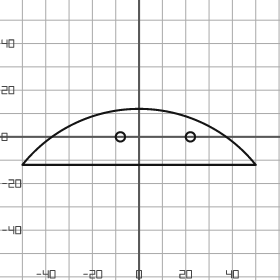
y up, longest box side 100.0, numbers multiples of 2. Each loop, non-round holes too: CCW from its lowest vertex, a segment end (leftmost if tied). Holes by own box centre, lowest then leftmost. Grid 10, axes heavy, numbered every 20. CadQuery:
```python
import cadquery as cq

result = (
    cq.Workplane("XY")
    .moveTo(-50.0, -12.0)
    .lineTo(50.0, -12.0)
    .threePointArc((0.0, 12.0), (-50.0, -12.0))
    .close()
    .moveTo(-8.0, 0.0)
    .circle(2.0)
    .moveTo(22.0, 0.0)
    .circle(2.0)
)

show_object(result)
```